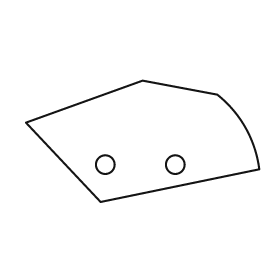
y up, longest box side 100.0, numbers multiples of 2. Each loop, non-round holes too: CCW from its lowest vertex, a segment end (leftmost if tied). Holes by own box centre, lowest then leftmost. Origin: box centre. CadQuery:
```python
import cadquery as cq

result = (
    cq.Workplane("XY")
    .moveTo(-18.0, -26.0)
    .lineTo(50.0, -12.0)
    .threePointArc((44.0, 6.0), (32.0, 20.0))
    .lineTo(0.0, 26.0)
    .lineTo(-50.0, 8.0)
    .close()
    .moveTo(-16.0, -10.0)
    .circle(4.0)
    .moveTo(14.0, -10.0)
    .circle(4.0)
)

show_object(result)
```